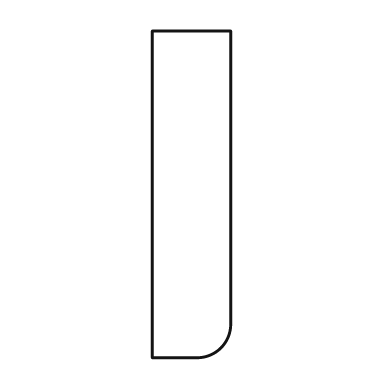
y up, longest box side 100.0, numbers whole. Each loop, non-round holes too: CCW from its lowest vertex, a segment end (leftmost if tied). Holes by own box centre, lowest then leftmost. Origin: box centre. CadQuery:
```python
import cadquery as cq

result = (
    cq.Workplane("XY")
    .moveTo(-12.0, -50.0)
    .lineTo(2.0, -50.0)
    .threePointArc((9.0, -47.0), (12.0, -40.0))
    .lineTo(12.0, 50.0)
    .lineTo(-12.0, 50.0)
    .close()
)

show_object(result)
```